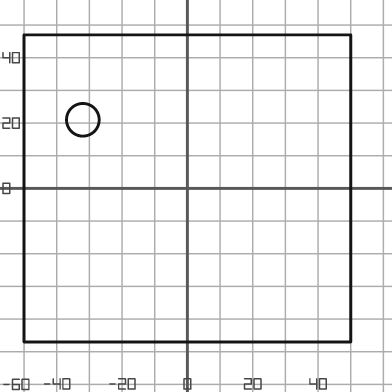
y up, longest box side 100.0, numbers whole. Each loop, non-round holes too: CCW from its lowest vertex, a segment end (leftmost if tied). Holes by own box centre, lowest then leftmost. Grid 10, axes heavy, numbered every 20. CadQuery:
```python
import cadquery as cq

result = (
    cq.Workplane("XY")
    .moveTo(-50.0, -47.0)
    .lineTo(50.0, -47.0)
    .lineTo(50.0, 47.0)
    .lineTo(-50.0, 47.0)
    .close()
    .moveTo(-32.0, 21.0)
    .circle(5.0)
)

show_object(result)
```